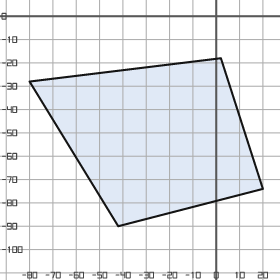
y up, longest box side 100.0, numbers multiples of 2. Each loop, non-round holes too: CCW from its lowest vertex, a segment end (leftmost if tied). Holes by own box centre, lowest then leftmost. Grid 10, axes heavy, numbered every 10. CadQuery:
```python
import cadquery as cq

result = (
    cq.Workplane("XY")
    .moveTo(-42.0, -90.0)
    .lineTo(20.0, -74.0)
    .lineTo(2.0, -18.0)
    .lineTo(-80.0, -28.0)
    .close()
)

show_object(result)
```